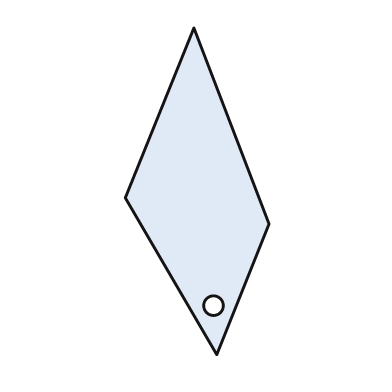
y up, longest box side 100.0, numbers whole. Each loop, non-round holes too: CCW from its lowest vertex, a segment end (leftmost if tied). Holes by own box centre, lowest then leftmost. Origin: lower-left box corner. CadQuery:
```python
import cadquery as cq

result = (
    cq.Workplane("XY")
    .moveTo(28.0, 0.0)
    .lineTo(44.0, 40.0)
    .lineTo(21.0, 100.0)
    .lineTo(0.0, 48.0)
    .close()
    .moveTo(27.0, 15.0)
    .circle(3.0)
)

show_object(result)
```